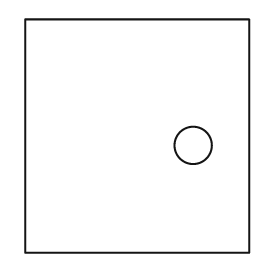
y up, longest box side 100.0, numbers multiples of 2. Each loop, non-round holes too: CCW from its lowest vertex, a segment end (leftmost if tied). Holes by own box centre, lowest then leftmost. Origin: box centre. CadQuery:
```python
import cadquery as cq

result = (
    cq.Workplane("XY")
    .moveTo(-48.0, -50.0)
    .lineTo(48.0, -50.0)
    .lineTo(48.0, 50.0)
    .lineTo(-48.0, 50.0)
    .close()
    .moveTo(24.0, -4.0)
    .circle(8.0)
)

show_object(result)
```